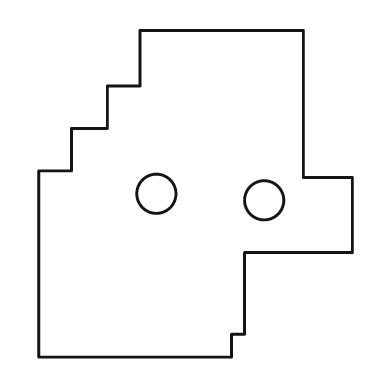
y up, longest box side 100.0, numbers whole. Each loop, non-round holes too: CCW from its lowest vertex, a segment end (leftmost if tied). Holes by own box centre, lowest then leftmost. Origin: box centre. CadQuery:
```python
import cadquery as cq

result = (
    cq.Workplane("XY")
    .moveTo(-48.0, -50.0)
    .lineTo(11.0, -50.0)
    .lineTo(11.0, -43.0)
    .lineTo(15.0, -43.0)
    .lineTo(15.0, -18.0)
    .lineTo(48.0, -18.0)
    .lineTo(48.0, 5.0)
    .lineTo(33.0, 5.0)
    .lineTo(33.0, 50.0)
    .lineTo(-17.0, 50.0)
    .lineTo(-17.0, 33.0)
    .lineTo(-27.0, 33.0)
    .lineTo(-27.0, 20.0)
    .lineTo(-38.0, 20.0)
    .lineTo(-38.0, 7.0)
    .lineTo(-48.0, 7.0)
    .close()
    .moveTo(21.0, -2.0)
    .circle(6.0)
    .moveTo(-12.0, 0.0)
    .circle(6.0)
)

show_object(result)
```